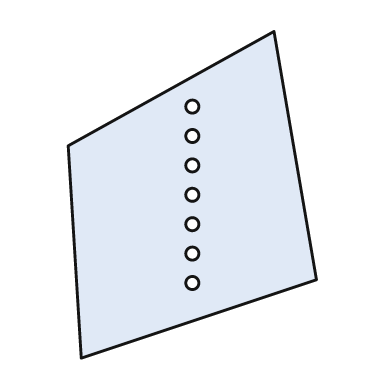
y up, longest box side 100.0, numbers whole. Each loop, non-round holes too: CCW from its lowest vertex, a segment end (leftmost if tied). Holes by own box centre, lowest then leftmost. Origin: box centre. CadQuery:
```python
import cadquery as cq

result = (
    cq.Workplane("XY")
    .moveTo(-34.0, -50.0)
    .lineTo(38.0, -26.0)
    .lineTo(25.0, 50.0)
    .lineTo(-38.0, 15.0)
    .close()
    .moveTo(0.0, -27.0)
    .circle(2.0)
    .moveTo(0.0, -18.0)
    .circle(2.0)
    .moveTo(0.0, -9.0)
    .circle(2.0)
    .moveTo(0.0, 0.0)
    .circle(2.0)
    .moveTo(0.0, 9.0)
    .circle(2.0)
    .moveTo(0.0, 18.0)
    .circle(2.0)
    .moveTo(0.0, 27.0)
    .circle(2.0)
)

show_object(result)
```